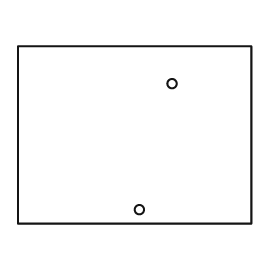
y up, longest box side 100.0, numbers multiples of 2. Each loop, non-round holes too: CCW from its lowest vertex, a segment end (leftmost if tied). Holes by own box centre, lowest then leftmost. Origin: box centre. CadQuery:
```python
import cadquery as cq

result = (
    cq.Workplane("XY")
    .moveTo(-50.0, -38.0)
    .lineTo(50.0, -38.0)
    .lineTo(50.0, 38.0)
    .lineTo(-50.0, 38.0)
    .close()
    .moveTo(2.0, -32.0)
    .circle(2.0)
    .moveTo(16.0, 22.0)
    .circle(2.0)
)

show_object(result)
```